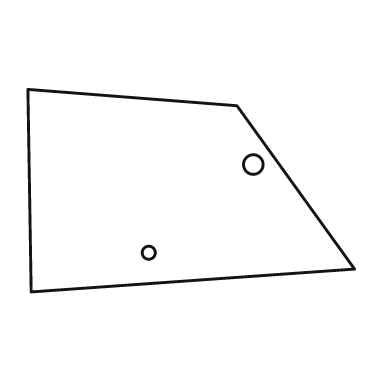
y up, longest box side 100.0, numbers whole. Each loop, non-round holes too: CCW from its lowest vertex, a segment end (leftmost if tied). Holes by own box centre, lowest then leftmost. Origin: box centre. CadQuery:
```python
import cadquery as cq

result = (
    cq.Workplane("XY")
    .moveTo(-49.0, -31.0)
    .lineTo(50.0, -24.0)
    .lineTo(14.0, 26.0)
    .lineTo(-50.0, 31.0)
    .close()
    .moveTo(-13.0, -19.0)
    .circle(2.0)
    .moveTo(19.0, 8.0)
    .circle(3.0)
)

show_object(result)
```